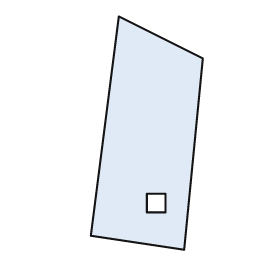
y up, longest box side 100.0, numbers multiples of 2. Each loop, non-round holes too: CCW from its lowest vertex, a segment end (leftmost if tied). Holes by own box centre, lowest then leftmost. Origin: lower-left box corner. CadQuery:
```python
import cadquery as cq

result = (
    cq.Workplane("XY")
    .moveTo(40.0, 0.0)
    .lineTo(48.0, 82.0)
    .lineTo(12.0, 100.0)
    .lineTo(0.0, 6.0)
    .close()
    .moveTo(24.0, 16.0)
    .lineTo(32.0, 16.0)
    .lineTo(32.0, 24.0)
    .lineTo(24.0, 24.0)
    .close()
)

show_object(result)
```